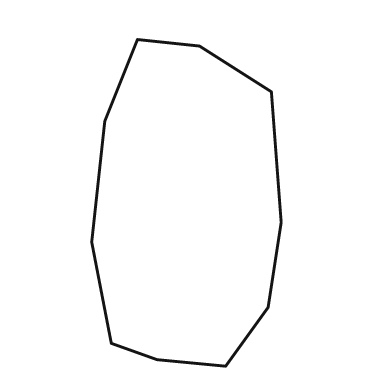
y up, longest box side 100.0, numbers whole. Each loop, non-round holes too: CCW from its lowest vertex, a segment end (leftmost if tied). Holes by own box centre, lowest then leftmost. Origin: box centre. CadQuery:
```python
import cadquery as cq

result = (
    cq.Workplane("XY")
    .moveTo(12.0, -50.0)
    .lineTo(25.0, -32.0)
    .lineTo(29.0, -6.0)
    .lineTo(26.0, 34.0)
    .lineTo(4.0, 48.0)
    .lineTo(-15.0, 50.0)
    .lineTo(-25.0, 25.0)
    .lineTo(-29.0, -12.0)
    .lineTo(-23.0, -43.0)
    .lineTo(-9.0, -48.0)
    .close()
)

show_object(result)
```